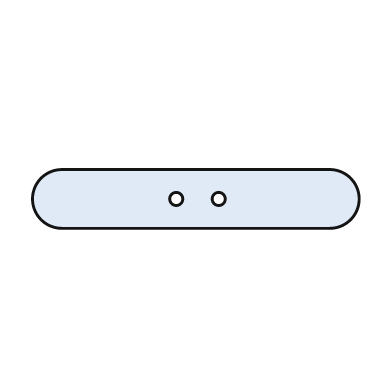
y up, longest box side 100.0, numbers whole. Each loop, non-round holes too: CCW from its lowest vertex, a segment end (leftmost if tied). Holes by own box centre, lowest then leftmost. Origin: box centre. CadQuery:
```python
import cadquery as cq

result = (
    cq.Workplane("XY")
    .moveTo(-41.0, -9.0)
    .lineTo(41.0, -9.0)
    .threePointArc((50.0, 0.0), (41.0, 9.0))
    .lineTo(-41.0, 9.0)
    .threePointArc((-50.0, 0.0), (-41.0, -9.0))
    .close()
    .moveTo(-6.0, 0.0)
    .circle(2.0)
    .moveTo(7.0, 0.0)
    .circle(2.0)
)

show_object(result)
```